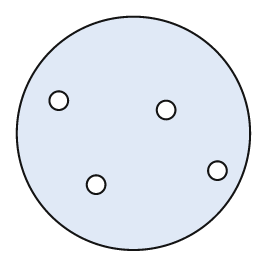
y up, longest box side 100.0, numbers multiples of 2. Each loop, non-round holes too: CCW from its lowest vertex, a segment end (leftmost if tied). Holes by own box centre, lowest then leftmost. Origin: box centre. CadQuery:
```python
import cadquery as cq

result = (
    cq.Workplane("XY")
    .moveTo(0.0, 0.0)
    .circle(50.0)
    .moveTo(-16.0, -22.0)
    .circle(4.0)
    .moveTo(36.0, -16.0)
    .circle(4.0)
    .moveTo(14.0, 10.0)
    .circle(4.0)
    .moveTo(-32.0, 14.0)
    .circle(4.0)
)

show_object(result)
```